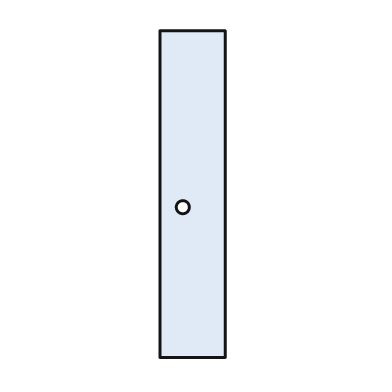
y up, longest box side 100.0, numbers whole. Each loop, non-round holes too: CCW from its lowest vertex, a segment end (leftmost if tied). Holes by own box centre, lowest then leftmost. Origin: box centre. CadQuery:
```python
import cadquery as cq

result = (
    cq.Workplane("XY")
    .moveTo(-10.0, -50.0)
    .lineTo(10.0, -50.0)
    .lineTo(10.0, 50.0)
    .lineTo(-10.0, 50.0)
    .close()
    .moveTo(-3.0, -4.0)
    .circle(2.0)
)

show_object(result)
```